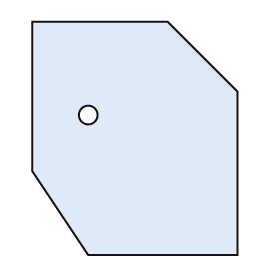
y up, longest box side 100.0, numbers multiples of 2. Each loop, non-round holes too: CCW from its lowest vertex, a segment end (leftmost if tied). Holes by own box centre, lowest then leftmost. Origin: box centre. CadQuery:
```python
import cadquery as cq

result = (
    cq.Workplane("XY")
    .moveTo(-20.0, -50.0)
    .lineTo(44.0, -50.0)
    .lineTo(44.0, 20.0)
    .lineTo(14.0, 50.0)
    .lineTo(-44.0, 50.0)
    .lineTo(-44.0, -14.0)
    .close()
    .moveTo(-20.0, 10.0)
    .circle(4.0)
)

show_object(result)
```